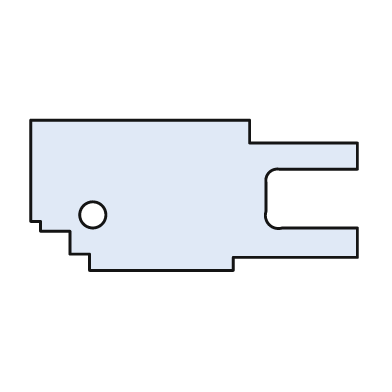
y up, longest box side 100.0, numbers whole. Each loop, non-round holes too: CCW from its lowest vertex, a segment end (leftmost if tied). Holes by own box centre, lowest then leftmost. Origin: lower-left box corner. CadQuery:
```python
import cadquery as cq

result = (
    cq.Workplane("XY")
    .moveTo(18.0, 0.0)
    .lineTo(62.0, 0.0)
    .lineTo(62.0, 4.0)
    .lineTo(100.0, 4.0)
    .lineTo(100.0, 13.0)
    .lineTo(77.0, 13.0)
    .threePointArc((73.0, 14.0), (72.0, 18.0))
    .lineTo(72.0, 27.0)
    .threePointArc((73.0, 30.0), (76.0, 31.0))
    .lineTo(100.0, 31.0)
    .lineTo(100.0, 39.0)
    .lineTo(67.0, 39.0)
    .lineTo(67.0, 46.0)
    .lineTo(0.0, 46.0)
    .lineTo(0.0, 15.0)
    .lineTo(3.0, 15.0)
    .lineTo(3.0, 12.0)
    .lineTo(12.0, 12.0)
    .lineTo(12.0, 5.0)
    .lineTo(18.0, 5.0)
    .close()
    .moveTo(19.0, 17.0)
    .circle(4.0)
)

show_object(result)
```